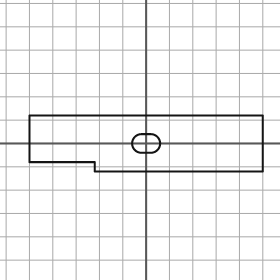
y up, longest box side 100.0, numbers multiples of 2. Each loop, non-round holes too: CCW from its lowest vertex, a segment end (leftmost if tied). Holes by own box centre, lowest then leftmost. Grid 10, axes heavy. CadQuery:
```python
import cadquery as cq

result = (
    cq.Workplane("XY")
    .moveTo(-22.0, -12.0)
    .lineTo(50.0, -12.0)
    .lineTo(50.0, 12.0)
    .lineTo(-50.0, 12.0)
    .lineTo(-50.0, -8.0)
    .lineTo(-22.0, -8.0)
    .close()
    .moveTo(-2.0, -4.0)
    .lineTo(2.0, -4.0)
    .threePointArc((6.0, 0.0), (2.0, 4.0))
    .lineTo(-2.0, 4.0)
    .threePointArc((-6.0, 0.0), (-2.0, -4.0))
    .close()
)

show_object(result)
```